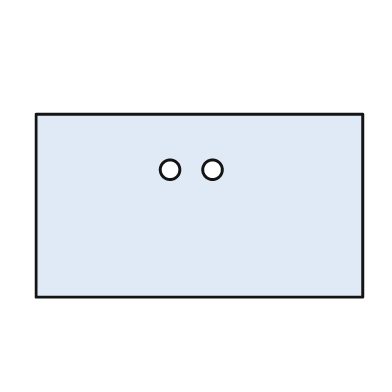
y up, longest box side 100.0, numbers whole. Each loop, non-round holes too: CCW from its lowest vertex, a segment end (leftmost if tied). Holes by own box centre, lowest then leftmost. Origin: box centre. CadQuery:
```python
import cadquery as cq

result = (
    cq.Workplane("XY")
    .moveTo(-50.0, -28.0)
    .lineTo(50.0, -28.0)
    .lineTo(50.0, 28.0)
    .lineTo(-50.0, 28.0)
    .close()
    .moveTo(-9.0, 11.0)
    .circle(3.0)
    .moveTo(4.0, 11.0)
    .circle(3.0)
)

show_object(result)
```